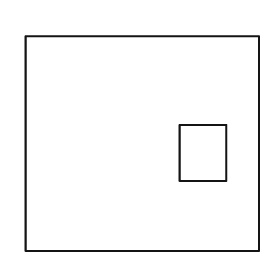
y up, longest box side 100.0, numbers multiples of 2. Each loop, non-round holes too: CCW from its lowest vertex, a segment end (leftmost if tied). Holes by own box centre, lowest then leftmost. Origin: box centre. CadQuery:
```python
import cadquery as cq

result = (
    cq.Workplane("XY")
    .moveTo(-50.0, -46.0)
    .lineTo(50.0, -46.0)
    .lineTo(50.0, 46.0)
    .lineTo(-50.0, 46.0)
    .close()
    .moveTo(16.0, -16.0)
    .lineTo(36.0, -16.0)
    .lineTo(36.0, 8.0)
    .lineTo(16.0, 8.0)
    .close()
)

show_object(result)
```